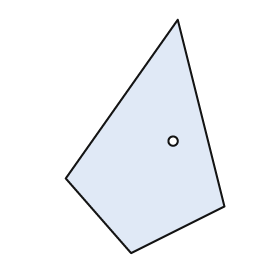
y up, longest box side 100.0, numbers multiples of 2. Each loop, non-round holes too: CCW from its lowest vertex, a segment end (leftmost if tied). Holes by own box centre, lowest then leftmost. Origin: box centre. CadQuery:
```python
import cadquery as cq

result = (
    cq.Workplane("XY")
    .moveTo(-6.0, -50.0)
    .lineTo(34.0, -30.0)
    .lineTo(14.0, 50.0)
    .lineTo(-34.0, -18.0)
    .close()
    .moveTo(12.0, -2.0)
    .circle(2.0)
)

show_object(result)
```